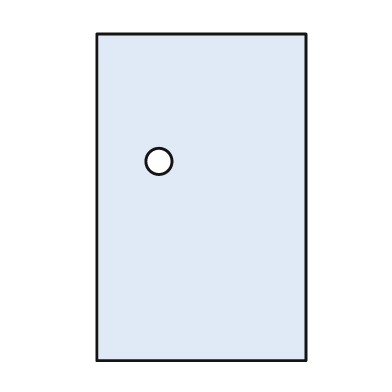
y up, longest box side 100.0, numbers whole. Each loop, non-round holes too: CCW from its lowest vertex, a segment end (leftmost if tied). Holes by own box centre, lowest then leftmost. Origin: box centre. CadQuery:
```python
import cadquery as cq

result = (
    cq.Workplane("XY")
    .moveTo(-32.0, -50.0)
    .lineTo(32.0, -50.0)
    .lineTo(32.0, 50.0)
    .lineTo(-32.0, 50.0)
    .close()
    .moveTo(-13.0, 11.0)
    .circle(4.0)
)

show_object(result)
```